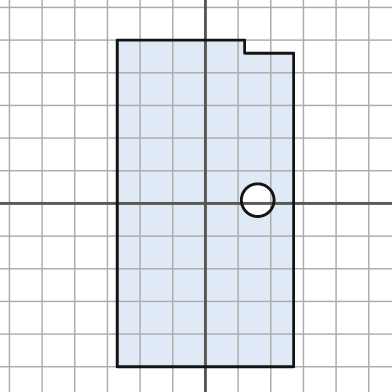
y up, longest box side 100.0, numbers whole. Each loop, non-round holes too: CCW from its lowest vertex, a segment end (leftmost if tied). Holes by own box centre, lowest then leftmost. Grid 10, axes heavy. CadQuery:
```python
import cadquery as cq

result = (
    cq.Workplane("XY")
    .moveTo(-27.0, -50.0)
    .lineTo(27.0, -50.0)
    .lineTo(27.0, 46.0)
    .lineTo(12.0, 46.0)
    .lineTo(12.0, 50.0)
    .lineTo(-27.0, 50.0)
    .close()
    .moveTo(16.0, 1.0)
    .circle(5.0)
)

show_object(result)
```